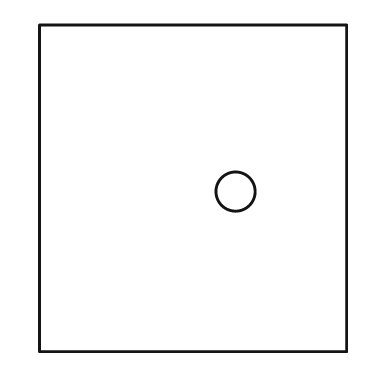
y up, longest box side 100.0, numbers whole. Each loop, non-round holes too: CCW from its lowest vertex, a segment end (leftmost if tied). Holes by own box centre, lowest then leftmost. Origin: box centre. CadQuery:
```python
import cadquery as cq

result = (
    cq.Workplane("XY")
    .moveTo(-47.0, -50.0)
    .lineTo(47.0, -50.0)
    .lineTo(47.0, 50.0)
    .lineTo(-47.0, 50.0)
    .close()
    .moveTo(13.0, -1.0)
    .circle(6.0)
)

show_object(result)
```